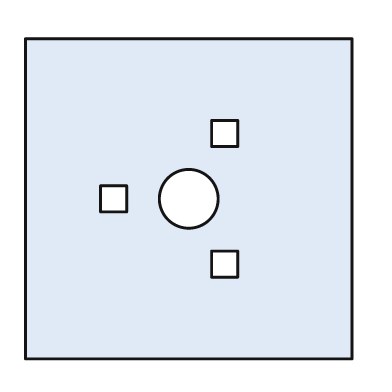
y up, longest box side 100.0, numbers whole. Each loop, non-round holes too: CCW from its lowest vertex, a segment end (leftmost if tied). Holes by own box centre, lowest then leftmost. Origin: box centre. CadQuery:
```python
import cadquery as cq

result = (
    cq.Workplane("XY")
    .moveTo(-50.0, -49.0)
    .lineTo(50.0, -49.0)
    .lineTo(50.0, 49.0)
    .lineTo(-50.0, 49.0)
    .close()
    .moveTo(7.0, -24.0)
    .lineTo(15.0, -24.0)
    .lineTo(15.0, -16.0)
    .lineTo(7.0, -16.0)
    .close()
    .moveTo(-27.0, -4.0)
    .lineTo(-19.0, -4.0)
    .lineTo(-19.0, 4.0)
    .lineTo(-27.0, 4.0)
    .close()
    .moveTo(0.0, 0.0)
    .circle(9.0)
    .moveTo(7.0, 16.0)
    .lineTo(15.0, 16.0)
    .lineTo(15.0, 24.0)
    .lineTo(7.0, 24.0)
    .close()
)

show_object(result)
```